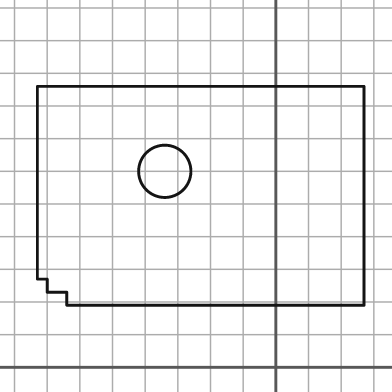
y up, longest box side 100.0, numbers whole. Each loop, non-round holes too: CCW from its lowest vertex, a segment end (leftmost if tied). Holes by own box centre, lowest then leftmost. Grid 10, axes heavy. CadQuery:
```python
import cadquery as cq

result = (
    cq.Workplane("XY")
    .moveTo(-64.0, 19.0)
    .lineTo(27.0, 19.0)
    .lineTo(27.0, 86.0)
    .lineTo(-73.0, 86.0)
    .lineTo(-73.0, 27.0)
    .lineTo(-70.0, 27.0)
    .lineTo(-70.0, 23.0)
    .lineTo(-64.0, 23.0)
    .close()
    .moveTo(-34.0, 60.0)
    .circle(8.0)
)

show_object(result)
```